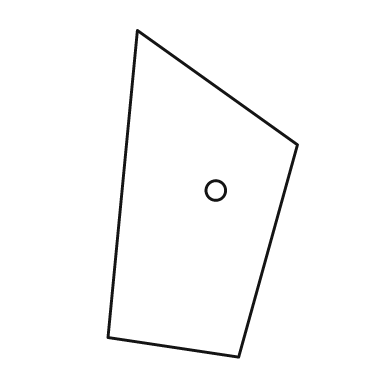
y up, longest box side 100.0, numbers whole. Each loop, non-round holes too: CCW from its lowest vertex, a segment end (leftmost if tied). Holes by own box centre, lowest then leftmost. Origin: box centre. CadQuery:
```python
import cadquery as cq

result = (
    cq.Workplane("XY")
    .moveTo(11.0, -50.0)
    .lineTo(29.0, 15.0)
    .lineTo(-20.0, 50.0)
    .lineTo(-29.0, -44.0)
    .close()
    .moveTo(4.0, 1.0)
    .circle(3.0)
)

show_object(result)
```